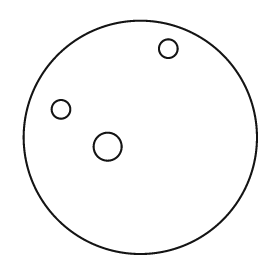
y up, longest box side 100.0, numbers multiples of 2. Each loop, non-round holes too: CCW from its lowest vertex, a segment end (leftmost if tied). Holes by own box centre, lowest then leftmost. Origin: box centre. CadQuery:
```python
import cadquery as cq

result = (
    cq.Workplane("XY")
    .moveTo(0.0, 0.0)
    .circle(50.0)
    .moveTo(-14.0, -4.0)
    .circle(6.0)
    .moveTo(-34.0, 12.0)
    .circle(4.0)
    .moveTo(12.0, 38.0)
    .circle(4.0)
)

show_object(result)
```